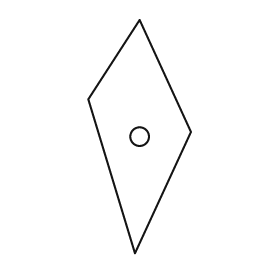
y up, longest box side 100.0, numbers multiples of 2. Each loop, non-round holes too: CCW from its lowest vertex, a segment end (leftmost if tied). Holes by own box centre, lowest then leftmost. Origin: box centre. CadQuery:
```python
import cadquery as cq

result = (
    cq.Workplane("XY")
    .moveTo(-2.0, -50.0)
    .lineTo(22.0, 2.0)
    .lineTo(0.0, 50.0)
    .lineTo(-22.0, 16.0)
    .close()
    .moveTo(0.0, 0.0)
    .circle(4.0)
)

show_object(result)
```